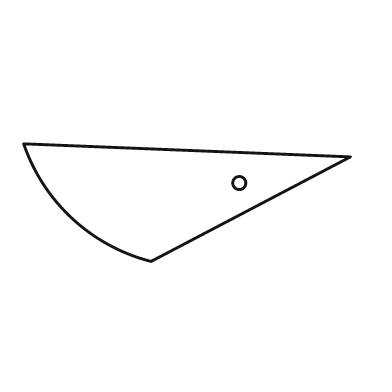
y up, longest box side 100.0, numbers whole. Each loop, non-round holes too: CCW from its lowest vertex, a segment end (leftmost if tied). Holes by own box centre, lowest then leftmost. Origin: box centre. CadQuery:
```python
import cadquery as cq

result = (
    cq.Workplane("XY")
    .moveTo(-11.0, -18.0)
    .lineTo(50.0, 14.0)
    .lineTo(-50.0, 18.0)
    .threePointArc((-35.0, -5.0), (-11.0, -18.0))
    .close()
    .moveTo(16.0, 6.0)
    .circle(2.0)
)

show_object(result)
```